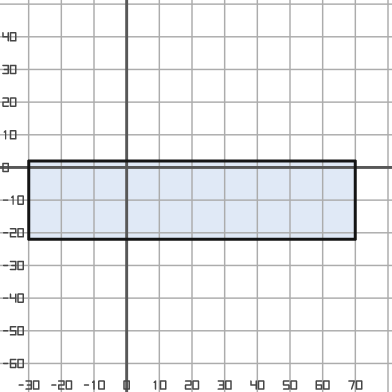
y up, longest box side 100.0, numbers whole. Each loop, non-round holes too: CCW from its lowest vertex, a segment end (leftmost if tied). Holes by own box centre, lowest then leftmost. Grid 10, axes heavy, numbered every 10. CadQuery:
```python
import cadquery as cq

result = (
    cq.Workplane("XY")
    .moveTo(-30.0, -22.0)
    .lineTo(70.0, -22.0)
    .lineTo(70.0, 2.0)
    .lineTo(-30.0, 2.0)
    .close()
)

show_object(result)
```